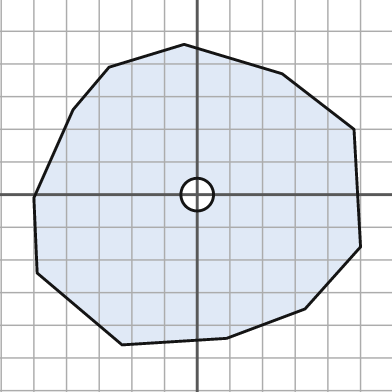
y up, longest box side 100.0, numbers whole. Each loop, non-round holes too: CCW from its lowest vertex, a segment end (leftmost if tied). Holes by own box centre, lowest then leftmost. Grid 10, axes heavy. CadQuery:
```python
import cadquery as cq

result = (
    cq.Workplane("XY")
    .moveTo(-23.0, -46.0)
    .lineTo(9.0, -44.0)
    .lineTo(33.0, -35.0)
    .lineTo(50.0, -16.0)
    .lineTo(48.0, 20.0)
    .lineTo(26.0, 37.0)
    .lineTo(-4.0, 46.0)
    .lineTo(-27.0, 39.0)
    .lineTo(-38.0, 26.0)
    .lineTo(-50.0, -1.0)
    .lineTo(-49.0, -24.0)
    .close()
    .moveTo(0.0, 0.0)
    .circle(5.0)
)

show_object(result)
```